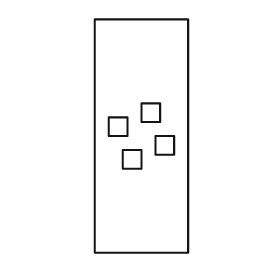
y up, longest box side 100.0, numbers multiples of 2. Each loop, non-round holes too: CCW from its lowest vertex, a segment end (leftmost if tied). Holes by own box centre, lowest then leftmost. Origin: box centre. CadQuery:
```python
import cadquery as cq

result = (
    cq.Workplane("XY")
    .moveTo(-20.0, -50.0)
    .lineTo(20.0, -50.0)
    .lineTo(20.0, 50.0)
    .lineTo(-20.0, 50.0)
    .close()
    .moveTo(-8.0, -14.0)
    .lineTo(0.0, -14.0)
    .lineTo(0.0, -6.0)
    .lineTo(-8.0, -6.0)
    .close()
    .moveTo(6.0, -8.0)
    .lineTo(14.0, -8.0)
    .lineTo(14.0, 0.0)
    .lineTo(6.0, 0.0)
    .close()
    .moveTo(-14.0, 0.0)
    .lineTo(-6.0, 0.0)
    .lineTo(-6.0, 8.0)
    .lineTo(-14.0, 8.0)
    .close()
    .moveTo(0.0, 6.0)
    .lineTo(8.0, 6.0)
    .lineTo(8.0, 14.0)
    .lineTo(0.0, 14.0)
    .close()
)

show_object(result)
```